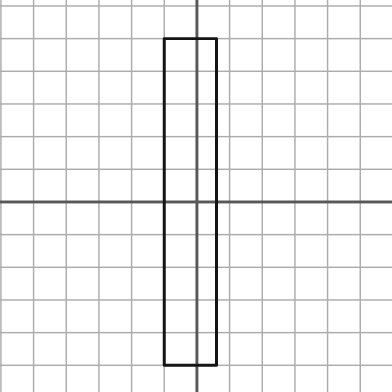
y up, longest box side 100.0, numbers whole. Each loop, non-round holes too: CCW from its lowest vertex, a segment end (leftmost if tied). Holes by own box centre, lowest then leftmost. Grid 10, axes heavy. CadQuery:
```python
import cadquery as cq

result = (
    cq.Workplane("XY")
    .moveTo(-10.0, -50.0)
    .lineTo(6.0, -50.0)
    .lineTo(6.0, 50.0)
    .lineTo(-10.0, 50.0)
    .close()
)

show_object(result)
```